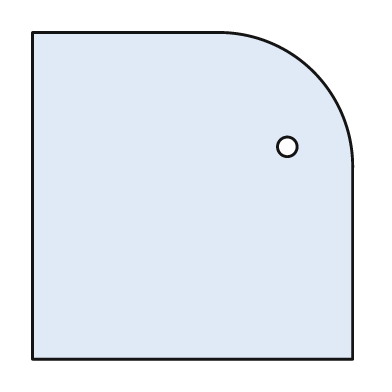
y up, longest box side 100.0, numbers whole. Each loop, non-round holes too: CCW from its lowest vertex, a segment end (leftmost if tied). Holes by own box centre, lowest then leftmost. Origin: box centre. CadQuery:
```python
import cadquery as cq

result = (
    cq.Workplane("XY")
    .moveTo(-49.0, -50.0)
    .lineTo(49.0, -50.0)
    .lineTo(49.0, 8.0)
    .threePointArc((37.0, 38.0), (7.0, 50.0))
    .lineTo(-49.0, 50.0)
    .close()
    .moveTo(29.0, 15.0)
    .circle(3.0)
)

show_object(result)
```